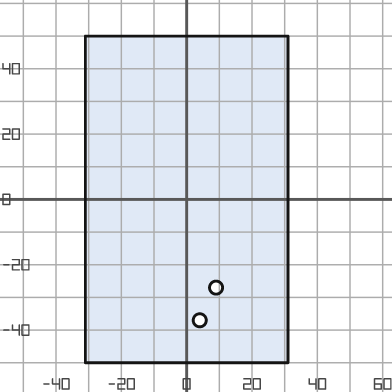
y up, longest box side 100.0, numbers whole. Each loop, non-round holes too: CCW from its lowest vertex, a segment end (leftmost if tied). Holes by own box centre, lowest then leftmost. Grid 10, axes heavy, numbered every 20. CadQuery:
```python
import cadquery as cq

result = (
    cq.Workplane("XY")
    .moveTo(-31.0, -50.0)
    .lineTo(31.0, -50.0)
    .lineTo(31.0, 50.0)
    .lineTo(-31.0, 50.0)
    .close()
    .moveTo(4.0, -37.0)
    .circle(2.0)
    .moveTo(9.0, -27.0)
    .circle(2.0)
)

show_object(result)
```